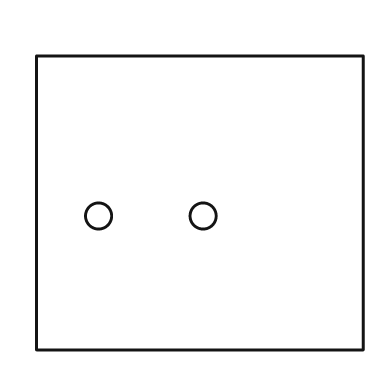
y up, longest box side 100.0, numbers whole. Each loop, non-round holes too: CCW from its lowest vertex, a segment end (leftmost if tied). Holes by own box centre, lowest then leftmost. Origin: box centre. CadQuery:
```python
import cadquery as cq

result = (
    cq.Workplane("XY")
    .moveTo(-50.0, -45.0)
    .lineTo(50.0, -45.0)
    .lineTo(50.0, 45.0)
    .lineTo(-50.0, 45.0)
    .close()
    .moveTo(-31.0, -4.0)
    .circle(4.0)
    .moveTo(1.0, -4.0)
    .circle(4.0)
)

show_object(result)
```